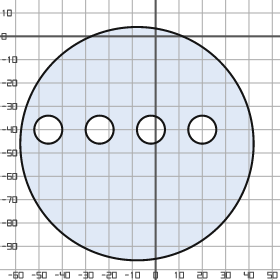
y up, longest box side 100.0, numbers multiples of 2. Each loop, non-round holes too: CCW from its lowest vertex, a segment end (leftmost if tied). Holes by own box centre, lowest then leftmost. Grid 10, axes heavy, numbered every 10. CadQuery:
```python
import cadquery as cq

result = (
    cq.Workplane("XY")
    .moveTo(-8.0, -46.0)
    .circle(50.0)
    .moveTo(-46.0, -40.0)
    .circle(6.0)
    .moveTo(-24.0, -40.0)
    .circle(6.0)
    .moveTo(-2.0, -40.0)
    .circle(6.0)
    .moveTo(20.0, -40.0)
    .circle(6.0)
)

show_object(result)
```